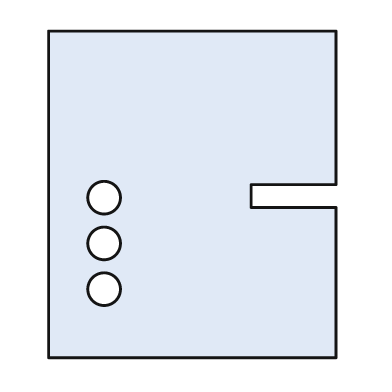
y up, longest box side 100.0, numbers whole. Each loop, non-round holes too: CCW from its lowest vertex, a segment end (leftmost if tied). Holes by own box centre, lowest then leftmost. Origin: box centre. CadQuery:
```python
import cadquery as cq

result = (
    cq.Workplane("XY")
    .moveTo(-44.0, -50.0)
    .lineTo(44.0, -50.0)
    .lineTo(44.0, -4.0)
    .lineTo(18.0, -4.0)
    .lineTo(18.0, 3.0)
    .lineTo(44.0, 3.0)
    .lineTo(44.0, 50.0)
    .lineTo(-44.0, 50.0)
    .close()
    .moveTo(-27.0, -29.0)
    .circle(5.0)
    .moveTo(-27.0, -15.0)
    .circle(5.0)
    .moveTo(-27.0, -1.0)
    .circle(5.0)
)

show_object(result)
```